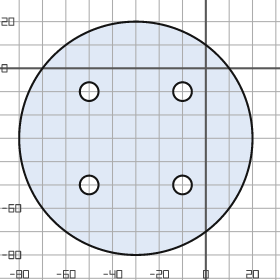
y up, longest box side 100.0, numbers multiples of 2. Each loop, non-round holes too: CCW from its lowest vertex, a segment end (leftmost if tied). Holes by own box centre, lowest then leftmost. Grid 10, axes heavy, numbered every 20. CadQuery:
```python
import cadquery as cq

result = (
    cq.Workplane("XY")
    .moveTo(-30.0, -30.0)
    .circle(50.0)
    .moveTo(-50.0, -50.0)
    .circle(4.0)
    .moveTo(-10.0, -50.0)
    .circle(4.0)
    .moveTo(-50.0, -10.0)
    .circle(4.0)
    .moveTo(-10.0, -10.0)
    .circle(4.0)
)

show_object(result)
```